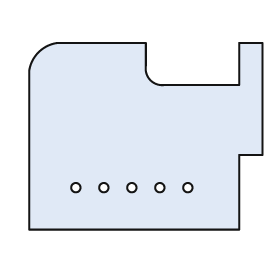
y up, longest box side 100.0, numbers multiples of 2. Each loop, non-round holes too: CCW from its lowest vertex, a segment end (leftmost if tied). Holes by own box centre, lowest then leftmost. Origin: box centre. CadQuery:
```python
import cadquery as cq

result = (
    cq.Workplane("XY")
    .moveTo(-50.0, -40.0)
    .lineTo(40.0, -40.0)
    .lineTo(40.0, -8.0)
    .lineTo(50.0, -8.0)
    .lineTo(50.0, 40.0)
    .lineTo(40.0, 40.0)
    .lineTo(40.0, 22.0)
    .lineTo(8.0, 22.0)
    .threePointArc((2.0, 24.0), (0.0, 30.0))
    .lineTo(0.0, 40.0)
    .lineTo(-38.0, 40.0)
    .threePointArc((-46.0, 36.0), (-50.0, 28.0))
    .close()
    .moveTo(-30.0, -22.0)
    .circle(2.0)
    .moveTo(-18.0, -22.0)
    .circle(2.0)
    .moveTo(-6.0, -22.0)
    .circle(2.0)
    .moveTo(6.0, -22.0)
    .circle(2.0)
    .moveTo(18.0, -22.0)
    .circle(2.0)
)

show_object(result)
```